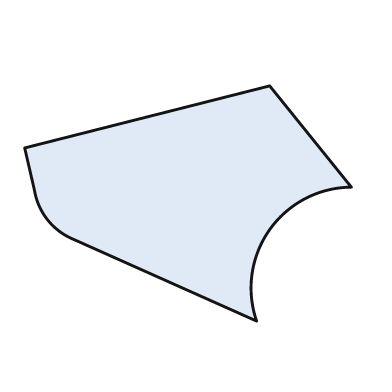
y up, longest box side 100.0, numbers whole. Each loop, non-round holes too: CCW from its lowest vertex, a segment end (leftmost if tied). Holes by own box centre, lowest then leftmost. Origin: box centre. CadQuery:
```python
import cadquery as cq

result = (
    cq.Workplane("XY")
    .moveTo(21.0, -36.0)
    .threePointArc((25.0, -8.0), (50.0, 5.0))
    .lineTo(25.0, 36.0)
    .lineTo(-50.0, 17.0)
    .lineTo(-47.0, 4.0)
    .threePointArc((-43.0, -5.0), (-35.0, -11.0))
    .close()
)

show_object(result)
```